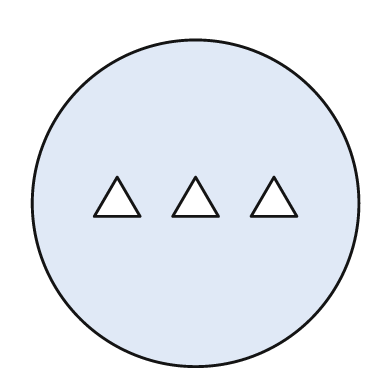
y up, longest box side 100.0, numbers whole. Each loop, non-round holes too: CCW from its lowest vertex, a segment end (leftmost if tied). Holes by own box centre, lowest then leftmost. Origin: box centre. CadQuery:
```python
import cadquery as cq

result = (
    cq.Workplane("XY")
    .moveTo(0.0, 0.0)
    .circle(50.0)
    .moveTo(-31.0, -4.0)
    .lineTo(-17.0, -4.0)
    .lineTo(-24.0, 8.0)
    .close()
    .moveTo(-7.0, -4.0)
    .lineTo(7.0, -4.0)
    .lineTo(0.0, 8.0)
    .close()
    .moveTo(17.0, -4.0)
    .lineTo(31.0, -4.0)
    .lineTo(24.0, 8.0)
    .close()
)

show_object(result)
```